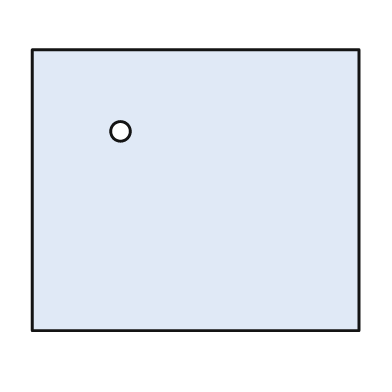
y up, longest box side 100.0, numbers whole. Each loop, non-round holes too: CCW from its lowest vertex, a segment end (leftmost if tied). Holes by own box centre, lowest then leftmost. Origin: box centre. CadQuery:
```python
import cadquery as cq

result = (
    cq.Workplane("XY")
    .moveTo(-50.0, -43.0)
    .lineTo(50.0, -43.0)
    .lineTo(50.0, 43.0)
    .lineTo(-50.0, 43.0)
    .close()
    .moveTo(-23.0, 18.0)
    .circle(3.0)
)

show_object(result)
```